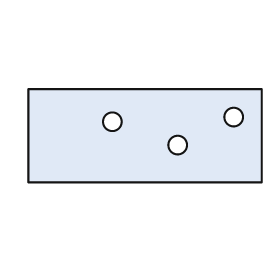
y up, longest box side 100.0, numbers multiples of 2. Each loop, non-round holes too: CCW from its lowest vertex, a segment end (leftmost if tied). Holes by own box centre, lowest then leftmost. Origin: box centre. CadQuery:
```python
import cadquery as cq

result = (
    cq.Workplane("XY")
    .moveTo(-50.0, -20.0)
    .lineTo(50.0, -20.0)
    .lineTo(50.0, 20.0)
    .lineTo(-50.0, 20.0)
    .close()
    .moveTo(14.0, -4.0)
    .circle(4.0)
    .moveTo(-14.0, 6.0)
    .circle(4.0)
    .moveTo(38.0, 8.0)
    .circle(4.0)
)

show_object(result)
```